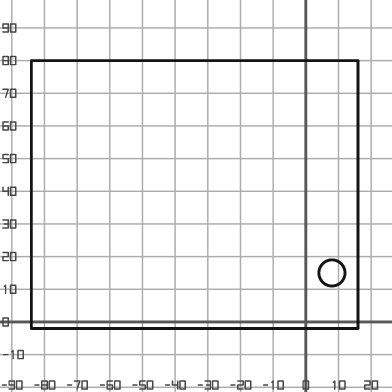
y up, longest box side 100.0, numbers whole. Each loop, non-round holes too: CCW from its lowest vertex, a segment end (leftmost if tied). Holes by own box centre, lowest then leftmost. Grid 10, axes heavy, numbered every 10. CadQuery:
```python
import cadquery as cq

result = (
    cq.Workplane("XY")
    .moveTo(-84.0, -2.0)
    .lineTo(16.0, -2.0)
    .lineTo(16.0, 80.0)
    .lineTo(-84.0, 80.0)
    .close()
    .moveTo(8.0, 15.0)
    .circle(4.0)
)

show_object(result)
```